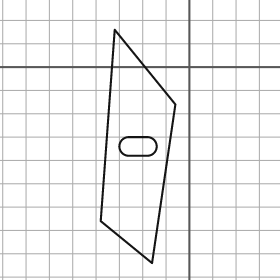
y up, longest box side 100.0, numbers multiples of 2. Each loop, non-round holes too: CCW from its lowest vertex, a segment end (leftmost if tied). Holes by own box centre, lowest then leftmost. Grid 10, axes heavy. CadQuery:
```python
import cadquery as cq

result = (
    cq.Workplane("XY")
    .moveTo(-16.0, -84.0)
    .lineTo(-6.0, -16.0)
    .lineTo(-32.0, 16.0)
    .lineTo(-38.0, -66.0)
    .close()
    .moveTo(-26.0, -38.0)
    .lineTo(-18.0, -38.0)
    .threePointArc((-14.0, -34.0), (-18.0, -30.0))
    .lineTo(-26.0, -30.0)
    .threePointArc((-30.0, -34.0), (-26.0, -38.0))
    .close()
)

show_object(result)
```